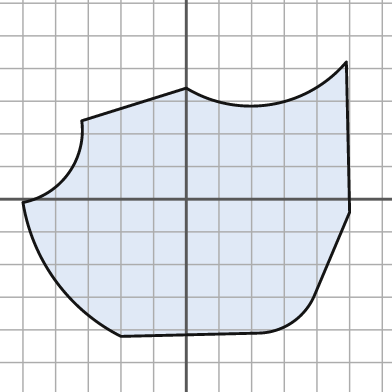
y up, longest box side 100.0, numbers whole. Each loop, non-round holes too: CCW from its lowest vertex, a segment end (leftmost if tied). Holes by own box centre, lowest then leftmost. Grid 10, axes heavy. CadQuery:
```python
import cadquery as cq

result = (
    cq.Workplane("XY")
    .moveTo(-20.0, -42.0)
    .lineTo(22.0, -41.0)
    .threePointArc((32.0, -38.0), (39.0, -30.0))
    .lineTo(50.0, -4.0)
    .lineTo(49.0, 42.0)
    .threePointArc((26.0, 29.0), (0.0, 34.0))
    .lineTo(-32.0, 24.0)
    .threePointArc((-36.0, 8.0), (-50.0, -1.0))
    .threePointArc((-40.0, -25.0), (-20.0, -42.0))
    .close()
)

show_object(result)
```